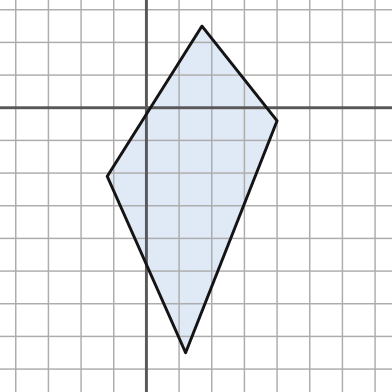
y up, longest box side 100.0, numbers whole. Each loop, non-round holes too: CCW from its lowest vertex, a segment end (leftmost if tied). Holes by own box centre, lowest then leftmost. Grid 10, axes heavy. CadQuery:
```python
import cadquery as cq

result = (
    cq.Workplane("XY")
    .moveTo(12.0, -75.0)
    .lineTo(40.0, -4.0)
    .lineTo(17.0, 25.0)
    .lineTo(-12.0, -21.0)
    .close()
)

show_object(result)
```